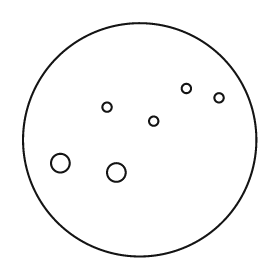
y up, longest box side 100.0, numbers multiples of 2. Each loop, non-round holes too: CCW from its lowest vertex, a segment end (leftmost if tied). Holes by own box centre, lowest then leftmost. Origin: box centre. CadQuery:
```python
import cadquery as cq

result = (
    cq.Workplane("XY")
    .moveTo(0.0, 0.0)
    .circle(50.0)
    .moveTo(-10.0, -14.0)
    .circle(4.0)
    .moveTo(-34.0, -10.0)
    .circle(4.0)
    .moveTo(6.0, 8.0)
    .circle(2.0)
    .moveTo(-14.0, 14.0)
    .circle(2.0)
    .moveTo(34.0, 18.0)
    .circle(2.0)
    .moveTo(20.0, 22.0)
    .circle(2.0)
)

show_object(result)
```